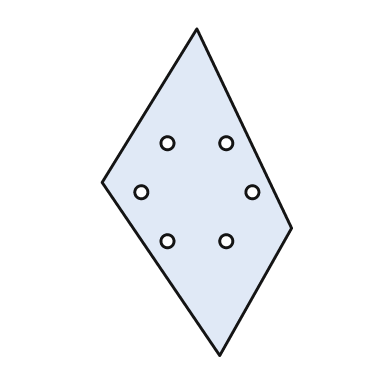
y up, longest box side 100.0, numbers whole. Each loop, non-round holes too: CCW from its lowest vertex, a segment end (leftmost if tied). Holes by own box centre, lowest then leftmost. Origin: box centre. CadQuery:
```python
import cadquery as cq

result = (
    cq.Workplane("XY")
    .moveTo(7.0, -50.0)
    .lineTo(29.0, -11.0)
    .lineTo(0.0, 50.0)
    .lineTo(-29.0, 3.0)
    .close()
    .moveTo(-9.0, -15.0)
    .circle(2.0)
    .moveTo(9.0, -15.0)
    .circle(2.0)
    .moveTo(-17.0, 0.0)
    .circle(2.0)
    .moveTo(17.0, 0.0)
    .circle(2.0)
    .moveTo(-9.0, 15.0)
    .circle(2.0)
    .moveTo(9.0, 15.0)
    .circle(2.0)
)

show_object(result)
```